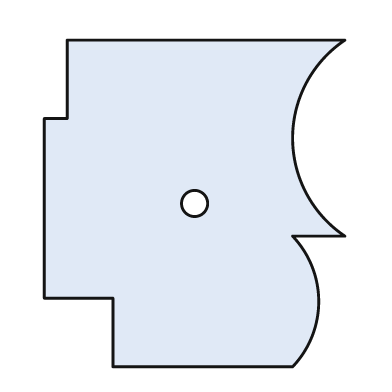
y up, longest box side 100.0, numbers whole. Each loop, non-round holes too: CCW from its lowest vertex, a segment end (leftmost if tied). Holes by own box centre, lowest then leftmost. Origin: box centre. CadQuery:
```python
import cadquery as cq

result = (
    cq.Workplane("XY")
    .moveTo(-25.0, -50.0)
    .lineTo(30.0, -50.0)
    .threePointArc((38.0, -30.0), (30.0, -10.0))
    .lineTo(46.0, -10.0)
    .threePointArc((30.0, 20.0), (46.0, 50.0))
    .lineTo(-39.0, 50.0)
    .lineTo(-39.0, 26.0)
    .lineTo(-46.0, 26.0)
    .lineTo(-46.0, -29.0)
    .lineTo(-25.0, -29.0)
    .close()
    .moveTo(0.0, 0.0)
    .circle(4.0)
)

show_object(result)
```